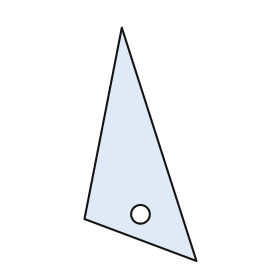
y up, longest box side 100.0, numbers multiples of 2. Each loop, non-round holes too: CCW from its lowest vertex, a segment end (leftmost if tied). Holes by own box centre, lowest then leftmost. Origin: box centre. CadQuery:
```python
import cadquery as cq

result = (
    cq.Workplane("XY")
    .moveTo(24.0, -50.0)
    .lineTo(-8.0, 50.0)
    .lineTo(-24.0, -32.0)
    .close()
    .moveTo(0.0, -30.0)
    .circle(4.0)
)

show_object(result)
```